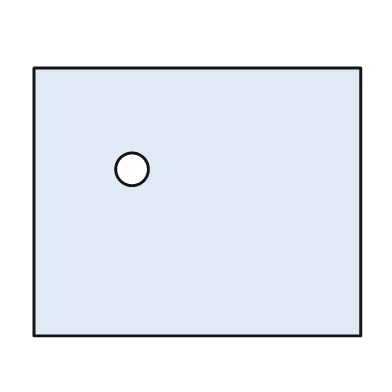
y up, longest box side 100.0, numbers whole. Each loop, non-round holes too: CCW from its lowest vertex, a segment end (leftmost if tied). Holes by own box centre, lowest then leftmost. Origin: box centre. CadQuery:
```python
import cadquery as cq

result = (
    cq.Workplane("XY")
    .moveTo(-50.0, -41.0)
    .lineTo(50.0, -41.0)
    .lineTo(50.0, 41.0)
    .lineTo(-50.0, 41.0)
    .close()
    .moveTo(-20.0, 10.0)
    .circle(5.0)
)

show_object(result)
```